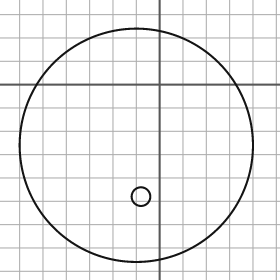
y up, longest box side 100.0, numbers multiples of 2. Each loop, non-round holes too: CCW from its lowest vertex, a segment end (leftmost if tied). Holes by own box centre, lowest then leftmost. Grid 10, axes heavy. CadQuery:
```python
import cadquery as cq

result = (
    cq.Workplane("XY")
    .moveTo(-10.0, -26.0)
    .circle(50.0)
    .moveTo(-8.0, -48.0)
    .circle(4.0)
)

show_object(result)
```